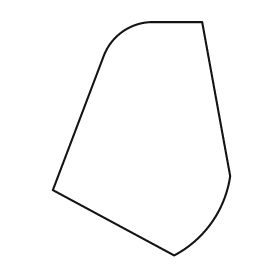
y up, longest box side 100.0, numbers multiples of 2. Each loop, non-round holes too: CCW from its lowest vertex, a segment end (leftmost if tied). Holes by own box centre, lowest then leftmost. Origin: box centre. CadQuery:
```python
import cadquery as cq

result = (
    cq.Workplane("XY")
    .moveTo(14.0, -50.0)
    .threePointArc((30.0, -36.0), (38.0, -16.0))
    .lineTo(26.0, 50.0)
    .lineTo(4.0, 50.0)
    .threePointArc((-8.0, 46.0), (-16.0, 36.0))
    .lineTo(-38.0, -22.0)
    .close()
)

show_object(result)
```